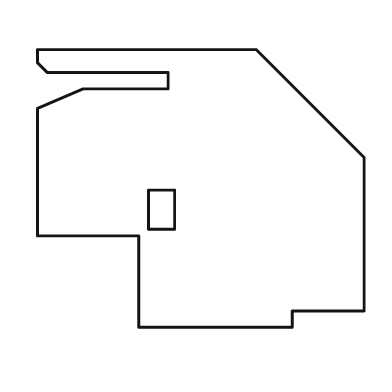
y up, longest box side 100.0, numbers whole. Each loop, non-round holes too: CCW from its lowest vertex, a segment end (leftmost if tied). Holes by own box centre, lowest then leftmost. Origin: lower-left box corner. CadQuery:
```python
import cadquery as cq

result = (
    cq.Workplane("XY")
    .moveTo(31.0, 0.0)
    .lineTo(78.0, 0.0)
    .lineTo(78.0, 5.0)
    .lineTo(100.0, 5.0)
    .lineTo(100.0, 52.0)
    .lineTo(67.0, 85.0)
    .lineTo(0.0, 85.0)
    .lineTo(0.0, 81.0)
    .lineTo(3.0, 78.0)
    .lineTo(40.0, 78.0)
    .lineTo(40.0, 73.0)
    .lineTo(14.0, 73.0)
    .lineTo(0.0, 67.0)
    .lineTo(0.0, 28.0)
    .lineTo(31.0, 28.0)
    .close()
    .moveTo(34.0, 30.0)
    .lineTo(42.0, 30.0)
    .lineTo(42.0, 42.0)
    .lineTo(34.0, 42.0)
    .close()
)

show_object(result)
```